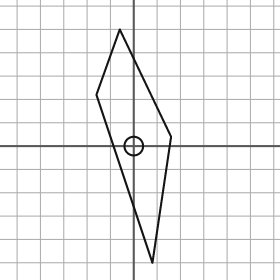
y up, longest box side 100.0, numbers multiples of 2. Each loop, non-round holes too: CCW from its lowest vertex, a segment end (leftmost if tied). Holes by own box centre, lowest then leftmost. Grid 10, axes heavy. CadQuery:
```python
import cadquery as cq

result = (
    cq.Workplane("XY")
    .moveTo(8.0, -50.0)
    .lineTo(16.0, 4.0)
    .lineTo(-6.0, 50.0)
    .lineTo(-16.0, 22.0)
    .close()
    .moveTo(0.0, 0.0)
    .circle(4.0)
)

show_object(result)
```